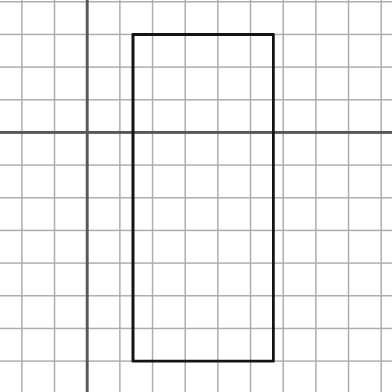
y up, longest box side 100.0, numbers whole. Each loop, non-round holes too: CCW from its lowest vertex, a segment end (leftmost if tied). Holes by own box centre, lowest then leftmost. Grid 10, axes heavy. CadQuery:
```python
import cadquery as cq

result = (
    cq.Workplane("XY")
    .moveTo(14.0, -70.0)
    .lineTo(57.0, -70.0)
    .lineTo(57.0, 30.0)
    .lineTo(14.0, 30.0)
    .close()
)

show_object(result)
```